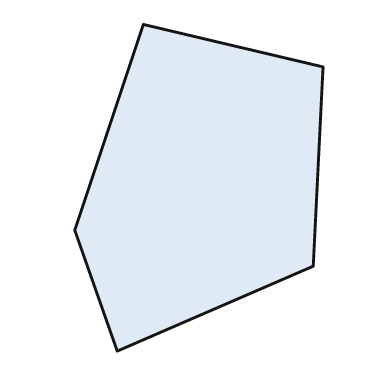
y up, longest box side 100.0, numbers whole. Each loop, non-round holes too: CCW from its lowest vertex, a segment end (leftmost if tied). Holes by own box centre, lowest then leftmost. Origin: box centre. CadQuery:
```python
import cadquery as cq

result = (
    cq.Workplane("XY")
    .moveTo(-25.0, -50.0)
    .lineTo(35.0, -24.0)
    .lineTo(38.0, 37.0)
    .lineTo(-17.0, 50.0)
    .lineTo(-38.0, -13.0)
    .close()
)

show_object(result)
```